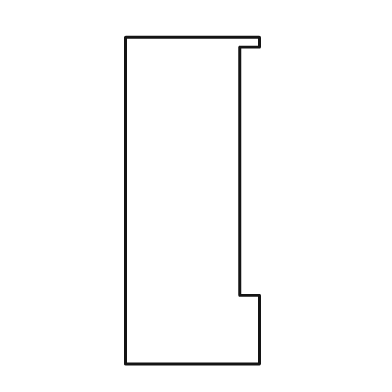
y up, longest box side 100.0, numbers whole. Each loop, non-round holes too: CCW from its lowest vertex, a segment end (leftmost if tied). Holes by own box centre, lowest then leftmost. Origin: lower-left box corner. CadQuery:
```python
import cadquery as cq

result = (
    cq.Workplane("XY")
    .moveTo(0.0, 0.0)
    .lineTo(41.0, 0.0)
    .lineTo(41.0, 21.0)
    .lineTo(35.0, 21.0)
    .lineTo(35.0, 97.0)
    .lineTo(41.0, 97.0)
    .lineTo(41.0, 100.0)
    .lineTo(0.0, 100.0)
    .close()
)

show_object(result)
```